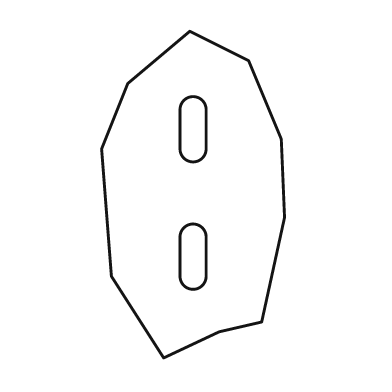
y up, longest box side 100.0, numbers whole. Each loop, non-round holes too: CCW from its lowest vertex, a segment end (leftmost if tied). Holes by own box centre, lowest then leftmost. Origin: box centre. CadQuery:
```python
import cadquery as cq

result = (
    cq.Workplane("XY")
    .moveTo(-9.0, -50.0)
    .lineTo(8.0, -42.0)
    .lineTo(21.0, -39.0)
    .lineTo(28.0, -7.0)
    .lineTo(27.0, 17.0)
    .lineTo(17.0, 41.0)
    .lineTo(-1.0, 50.0)
    .lineTo(-20.0, 34.0)
    .lineTo(-28.0, 14.0)
    .lineTo(-25.0, -25.0)
    .close()
    .moveTo(-4.0, -25.0)
    .threePointArc((0.0, -29.0), (4.0, -25.0))
    .lineTo(4.0, -13.0)
    .threePointArc((0.0, -9.0), (-4.0, -13.0))
    .close()
    .moveTo(-4.0, 14.0)
    .threePointArc((0.0, 10.0), (4.0, 14.0))
    .lineTo(4.0, 26.0)
    .threePointArc((0.0, 30.0), (-4.0, 26.0))
    .close()
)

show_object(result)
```